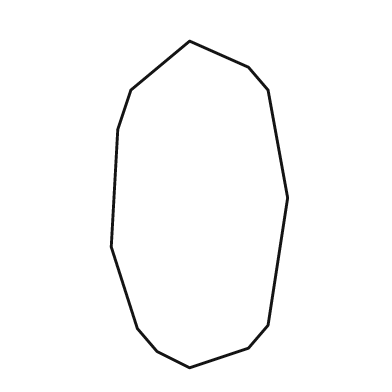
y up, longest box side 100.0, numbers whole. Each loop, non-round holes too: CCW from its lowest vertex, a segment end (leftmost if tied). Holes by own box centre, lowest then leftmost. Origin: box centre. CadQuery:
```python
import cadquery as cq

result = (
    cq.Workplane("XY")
    .moveTo(-3.0, -50.0)
    .lineTo(15.0, -44.0)
    .lineTo(21.0, -37.0)
    .lineTo(27.0, 2.0)
    .lineTo(21.0, 35.0)
    .lineTo(15.0, 42.0)
    .lineTo(-3.0, 50.0)
    .lineTo(-21.0, 35.0)
    .lineTo(-25.0, 23.0)
    .lineTo(-27.0, -13.0)
    .lineTo(-19.0, -38.0)
    .lineTo(-13.0, -45.0)
    .close()
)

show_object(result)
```